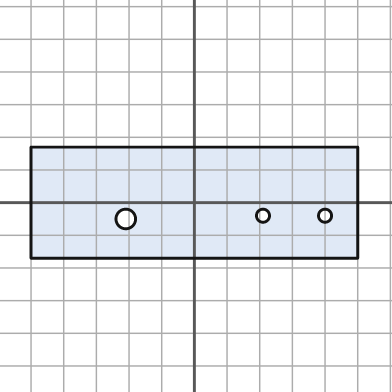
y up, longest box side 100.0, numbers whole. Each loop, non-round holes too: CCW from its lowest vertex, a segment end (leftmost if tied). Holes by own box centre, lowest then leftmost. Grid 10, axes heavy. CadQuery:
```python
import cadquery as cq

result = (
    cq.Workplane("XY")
    .moveTo(-50.0, -17.0)
    .lineTo(50.0, -17.0)
    .lineTo(50.0, 17.0)
    .lineTo(-50.0, 17.0)
    .close()
    .moveTo(-21.0, -5.0)
    .circle(3.0)
    .moveTo(21.0, -4.0)
    .circle(2.0)
    .moveTo(40.0, -4.0)
    .circle(2.0)
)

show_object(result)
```